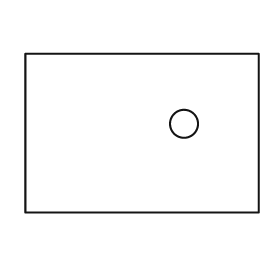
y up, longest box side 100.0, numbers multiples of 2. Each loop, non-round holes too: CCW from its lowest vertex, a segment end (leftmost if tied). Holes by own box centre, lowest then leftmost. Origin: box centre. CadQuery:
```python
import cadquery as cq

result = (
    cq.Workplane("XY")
    .moveTo(-50.0, -34.0)
    .lineTo(50.0, -34.0)
    .lineTo(50.0, 34.0)
    .lineTo(-50.0, 34.0)
    .close()
    .moveTo(18.0, 4.0)
    .circle(6.0)
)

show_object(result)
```